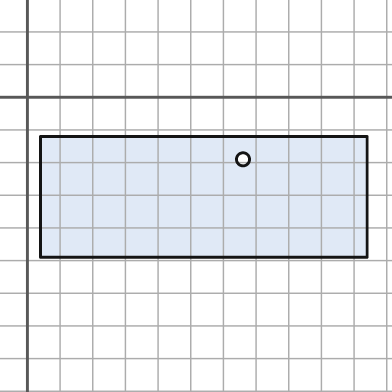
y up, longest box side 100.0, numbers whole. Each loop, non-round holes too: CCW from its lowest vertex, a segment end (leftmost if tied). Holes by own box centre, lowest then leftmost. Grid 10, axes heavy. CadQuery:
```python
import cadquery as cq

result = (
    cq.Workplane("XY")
    .moveTo(4.0, -49.0)
    .lineTo(104.0, -49.0)
    .lineTo(104.0, -12.0)
    .lineTo(4.0, -12.0)
    .close()
    .moveTo(66.0, -19.0)
    .circle(2.0)
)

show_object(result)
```